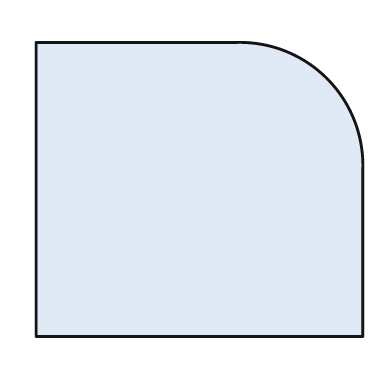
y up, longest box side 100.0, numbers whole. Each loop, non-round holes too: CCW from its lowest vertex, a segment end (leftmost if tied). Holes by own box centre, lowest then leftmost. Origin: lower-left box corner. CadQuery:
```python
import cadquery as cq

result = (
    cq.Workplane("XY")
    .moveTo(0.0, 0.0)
    .lineTo(100.0, 0.0)
    .lineTo(100.0, 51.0)
    .threePointArc((89.0, 79.0), (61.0, 90.0))
    .lineTo(0.0, 90.0)
    .close()
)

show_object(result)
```